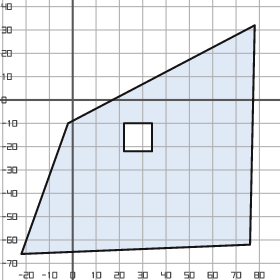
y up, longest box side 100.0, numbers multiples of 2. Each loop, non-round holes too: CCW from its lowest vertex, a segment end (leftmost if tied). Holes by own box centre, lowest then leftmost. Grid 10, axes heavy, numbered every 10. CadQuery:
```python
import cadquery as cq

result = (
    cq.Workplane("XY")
    .moveTo(-22.0, -66.0)
    .lineTo(76.0, -62.0)
    .lineTo(78.0, 32.0)
    .lineTo(-2.0, -10.0)
    .close()
    .moveTo(22.0, -22.0)
    .lineTo(34.0, -22.0)
    .lineTo(34.0, -10.0)
    .lineTo(22.0, -10.0)
    .close()
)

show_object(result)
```